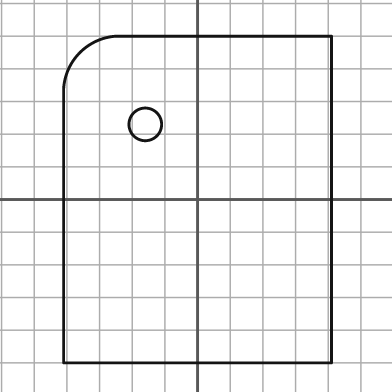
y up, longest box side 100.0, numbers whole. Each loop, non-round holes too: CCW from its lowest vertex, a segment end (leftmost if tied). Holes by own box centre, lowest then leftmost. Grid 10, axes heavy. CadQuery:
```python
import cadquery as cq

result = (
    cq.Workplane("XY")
    .moveTo(-41.0, -50.0)
    .lineTo(41.0, -50.0)
    .lineTo(41.0, 50.0)
    .lineTo(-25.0, 50.0)
    .threePointArc((-36.0, 45.0), (-41.0, 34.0))
    .close()
    .moveTo(-16.0, 23.0)
    .circle(5.0)
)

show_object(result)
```